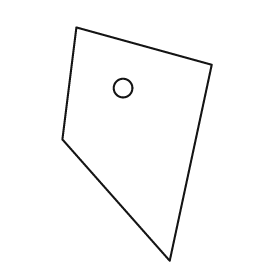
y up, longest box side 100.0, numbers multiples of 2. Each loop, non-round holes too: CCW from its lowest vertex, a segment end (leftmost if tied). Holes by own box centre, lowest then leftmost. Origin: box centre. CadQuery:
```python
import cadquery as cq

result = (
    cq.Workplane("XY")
    .moveTo(14.0, -50.0)
    .lineTo(32.0, 34.0)
    .lineTo(-26.0, 50.0)
    .lineTo(-32.0, 2.0)
    .close()
    .moveTo(-6.0, 24.0)
    .circle(4.0)
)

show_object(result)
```